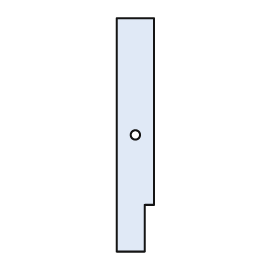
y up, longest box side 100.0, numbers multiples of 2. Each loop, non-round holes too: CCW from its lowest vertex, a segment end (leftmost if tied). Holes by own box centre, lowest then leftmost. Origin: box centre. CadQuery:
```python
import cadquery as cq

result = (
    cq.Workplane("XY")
    .moveTo(-8.0, -50.0)
    .lineTo(4.0, -50.0)
    .lineTo(4.0, -30.0)
    .lineTo(8.0, -30.0)
    .lineTo(8.0, 50.0)
    .lineTo(-8.0, 50.0)
    .close()
    .moveTo(0.0, 0.0)
    .circle(2.0)
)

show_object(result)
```